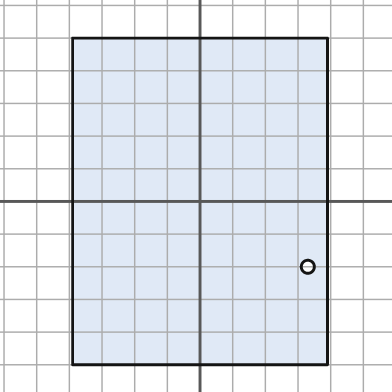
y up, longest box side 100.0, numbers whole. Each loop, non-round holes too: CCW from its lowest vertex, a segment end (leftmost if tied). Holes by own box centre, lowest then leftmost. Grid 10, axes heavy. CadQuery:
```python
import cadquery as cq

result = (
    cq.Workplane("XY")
    .moveTo(-39.0, -50.0)
    .lineTo(39.0, -50.0)
    .lineTo(39.0, 50.0)
    .lineTo(-39.0, 50.0)
    .close()
    .moveTo(33.0, -20.0)
    .circle(2.0)
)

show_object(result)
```